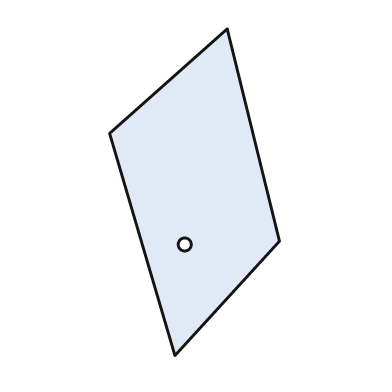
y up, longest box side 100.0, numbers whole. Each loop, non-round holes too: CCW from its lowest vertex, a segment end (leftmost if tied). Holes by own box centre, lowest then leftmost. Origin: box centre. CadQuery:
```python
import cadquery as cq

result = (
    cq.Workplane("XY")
    .moveTo(-6.0, -50.0)
    .lineTo(26.0, -15.0)
    .lineTo(10.0, 50.0)
    .lineTo(-26.0, 18.0)
    .close()
    .moveTo(-3.0, -16.0)
    .circle(2.0)
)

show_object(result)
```